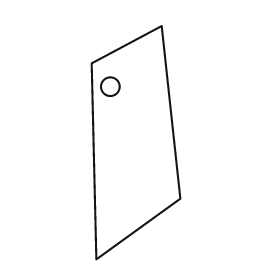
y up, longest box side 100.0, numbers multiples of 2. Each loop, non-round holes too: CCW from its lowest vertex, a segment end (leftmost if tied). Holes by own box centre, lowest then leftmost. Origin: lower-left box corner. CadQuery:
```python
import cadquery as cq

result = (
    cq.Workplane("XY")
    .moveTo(2.0, 0.0)
    .lineTo(38.0, 26.0)
    .lineTo(30.0, 100.0)
    .lineTo(0.0, 84.0)
    .close()
    .moveTo(8.0, 74.0)
    .circle(4.0)
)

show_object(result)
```